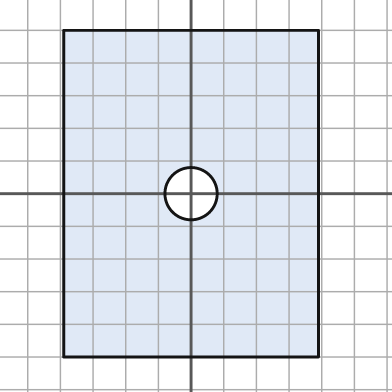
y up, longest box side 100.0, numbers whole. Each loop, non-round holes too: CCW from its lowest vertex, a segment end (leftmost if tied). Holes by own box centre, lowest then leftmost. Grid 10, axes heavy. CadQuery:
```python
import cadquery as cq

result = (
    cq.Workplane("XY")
    .moveTo(-39.0, -50.0)
    .lineTo(39.0, -50.0)
    .lineTo(39.0, 50.0)
    .lineTo(-39.0, 50.0)
    .close()
    .moveTo(0.0, 0.0)
    .circle(8.0)
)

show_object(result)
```